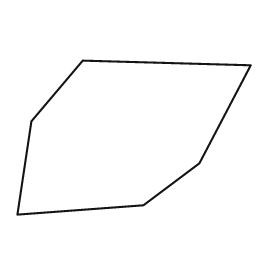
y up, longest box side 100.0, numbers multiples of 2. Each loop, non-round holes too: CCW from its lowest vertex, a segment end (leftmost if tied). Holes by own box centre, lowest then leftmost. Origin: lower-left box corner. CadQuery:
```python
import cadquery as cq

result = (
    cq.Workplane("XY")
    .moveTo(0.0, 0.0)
    .lineTo(54.0, 4.0)
    .lineTo(78.0, 22.0)
    .lineTo(100.0, 64.0)
    .lineTo(28.0, 66.0)
    .lineTo(6.0, 40.0)
    .close()
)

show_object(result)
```